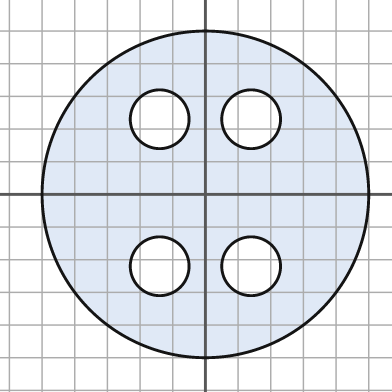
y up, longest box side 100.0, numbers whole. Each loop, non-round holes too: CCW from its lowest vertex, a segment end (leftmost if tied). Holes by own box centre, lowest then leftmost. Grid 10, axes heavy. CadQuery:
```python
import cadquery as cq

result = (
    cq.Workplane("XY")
    .moveTo(0.0, 0.0)
    .circle(50.0)
    .moveTo(-14.0, -22.0)
    .circle(9.0)
    .moveTo(14.0, -22.0)
    .circle(9.0)
    .moveTo(-14.0, 23.0)
    .circle(9.0)
    .moveTo(14.0, 23.0)
    .circle(9.0)
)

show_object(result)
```